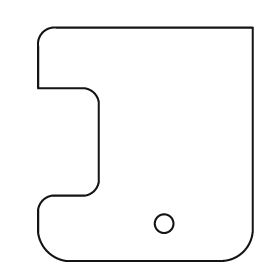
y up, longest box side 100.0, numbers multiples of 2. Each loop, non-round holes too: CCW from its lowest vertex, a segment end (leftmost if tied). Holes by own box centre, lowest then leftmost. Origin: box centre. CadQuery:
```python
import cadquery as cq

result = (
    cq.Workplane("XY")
    .moveTo(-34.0, -50.0)
    .lineTo(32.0, -50.0)
    .threePointArc((42.0, -46.0), (46.0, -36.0))
    .lineTo(46.0, 50.0)
    .lineTo(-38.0, 50.0)
    .threePointArc((-44.0, 48.0), (-46.0, 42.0))
    .lineTo(-46.0, 24.0)
    .lineTo(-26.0, 24.0)
    .threePointArc((-22.0, 22.0), (-20.0, 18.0))
    .lineTo(-20.0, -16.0)
    .threePointArc((-22.0, -20.0), (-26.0, -22.0))
    .lineTo(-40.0, -22.0)
    .threePointArc((-44.0, -24.0), (-46.0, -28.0))
    .lineTo(-46.0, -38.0)
    .threePointArc((-42.0, -46.0), (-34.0, -50.0))
    .close()
    .moveTo(8.0, -34.0)
    .circle(4.0)
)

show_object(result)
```